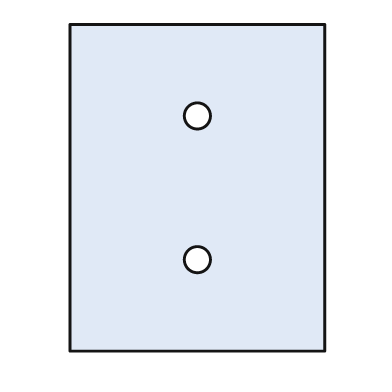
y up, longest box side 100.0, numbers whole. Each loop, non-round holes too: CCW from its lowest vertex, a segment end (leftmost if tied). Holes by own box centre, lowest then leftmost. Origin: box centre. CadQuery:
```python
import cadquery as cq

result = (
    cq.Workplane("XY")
    .moveTo(-39.0, -50.0)
    .lineTo(39.0, -50.0)
    .lineTo(39.0, 50.0)
    .lineTo(-39.0, 50.0)
    .close()
    .moveTo(0.0, -22.0)
    .circle(4.0)
    .moveTo(0.0, 22.0)
    .circle(4.0)
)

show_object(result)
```